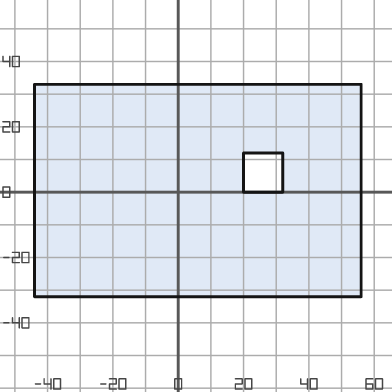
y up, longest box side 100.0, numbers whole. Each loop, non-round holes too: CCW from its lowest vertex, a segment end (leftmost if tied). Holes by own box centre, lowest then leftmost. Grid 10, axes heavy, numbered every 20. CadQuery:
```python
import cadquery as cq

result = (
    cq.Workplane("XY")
    .moveTo(-44.0, -32.0)
    .lineTo(56.0, -32.0)
    .lineTo(56.0, 33.0)
    .lineTo(-44.0, 33.0)
    .close()
    .moveTo(20.0, 0.0)
    .lineTo(32.0, 0.0)
    .lineTo(32.0, 12.0)
    .lineTo(20.0, 12.0)
    .close()
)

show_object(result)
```